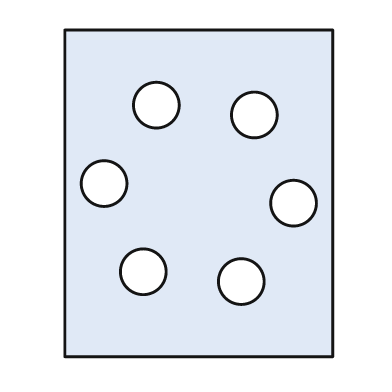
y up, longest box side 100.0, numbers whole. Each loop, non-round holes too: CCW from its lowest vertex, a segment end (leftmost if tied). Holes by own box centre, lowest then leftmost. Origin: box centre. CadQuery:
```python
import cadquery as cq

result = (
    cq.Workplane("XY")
    .moveTo(-41.0, -50.0)
    .lineTo(41.0, -50.0)
    .lineTo(41.0, 50.0)
    .lineTo(-41.0, 50.0)
    .close()
    .moveTo(13.0, -27.0)
    .circle(7.0)
    .moveTo(-17.0, -24.0)
    .circle(7.0)
    .moveTo(29.0, -3.0)
    .circle(7.0)
    .moveTo(-29.0, 3.0)
    .circle(7.0)
    .moveTo(17.0, 24.0)
    .circle(7.0)
    .moveTo(-13.0, 27.0)
    .circle(7.0)
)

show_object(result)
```